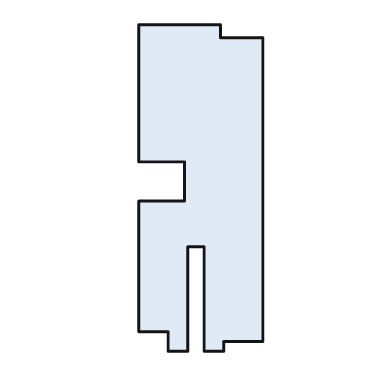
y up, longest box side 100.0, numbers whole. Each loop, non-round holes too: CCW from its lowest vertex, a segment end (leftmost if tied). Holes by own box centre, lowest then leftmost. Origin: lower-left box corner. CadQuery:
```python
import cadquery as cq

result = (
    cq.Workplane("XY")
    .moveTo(9.0, 0.0)
    .lineTo(15.0, 0.0)
    .lineTo(15.0, 32.0)
    .lineTo(20.0, 32.0)
    .lineTo(20.0, 0.0)
    .lineTo(26.0, 0.0)
    .lineTo(26.0, 3.0)
    .lineTo(38.0, 3.0)
    .lineTo(38.0, 96.0)
    .lineTo(25.0, 96.0)
    .lineTo(25.0, 100.0)
    .lineTo(0.0, 100.0)
    .lineTo(0.0, 58.0)
    .lineTo(14.0, 58.0)
    .lineTo(14.0, 46.0)
    .lineTo(0.0, 46.0)
    .lineTo(0.0, 6.0)
    .lineTo(9.0, 6.0)
    .close()
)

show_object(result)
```